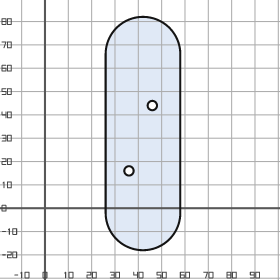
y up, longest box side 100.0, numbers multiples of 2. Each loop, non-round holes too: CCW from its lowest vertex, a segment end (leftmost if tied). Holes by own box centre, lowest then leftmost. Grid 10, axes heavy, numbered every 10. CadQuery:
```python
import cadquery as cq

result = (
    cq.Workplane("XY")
    .moveTo(26.0, -2.0)
    .threePointArc((42.0, -18.0), (58.0, -2.0))
    .lineTo(58.0, 66.0)
    .threePointArc((42.0, 82.0), (26.0, 66.0))
    .close()
    .moveTo(36.0, 16.0)
    .circle(2.0)
    .moveTo(46.0, 44.0)
    .circle(2.0)
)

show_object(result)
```